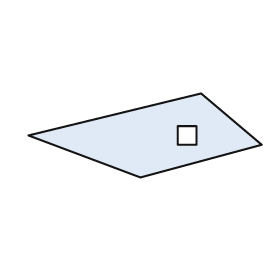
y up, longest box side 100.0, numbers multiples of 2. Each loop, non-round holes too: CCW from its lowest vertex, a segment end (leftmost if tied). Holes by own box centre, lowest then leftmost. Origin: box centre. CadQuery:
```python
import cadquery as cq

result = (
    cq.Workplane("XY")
    .moveTo(-2.0, -18.0)
    .lineTo(50.0, -4.0)
    .lineTo(24.0, 18.0)
    .lineTo(-50.0, 0.0)
    .close()
    .moveTo(14.0, -4.0)
    .lineTo(22.0, -4.0)
    .lineTo(22.0, 4.0)
    .lineTo(14.0, 4.0)
    .close()
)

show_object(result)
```